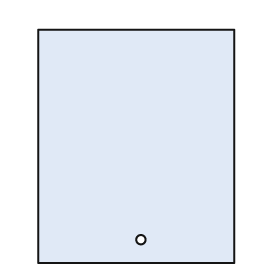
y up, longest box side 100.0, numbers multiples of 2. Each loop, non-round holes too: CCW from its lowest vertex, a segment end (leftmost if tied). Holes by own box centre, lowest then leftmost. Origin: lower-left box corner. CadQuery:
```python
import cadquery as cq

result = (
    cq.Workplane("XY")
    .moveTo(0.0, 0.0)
    .lineTo(84.0, 0.0)
    .lineTo(84.0, 100.0)
    .lineTo(0.0, 100.0)
    .close()
    .moveTo(44.0, 10.0)
    .circle(2.0)
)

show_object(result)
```